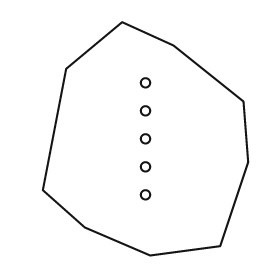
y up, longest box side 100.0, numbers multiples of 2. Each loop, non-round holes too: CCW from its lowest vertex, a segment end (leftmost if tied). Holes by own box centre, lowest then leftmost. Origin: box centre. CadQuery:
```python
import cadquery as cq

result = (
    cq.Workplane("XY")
    .moveTo(2.0, -50.0)
    .lineTo(32.0, -46.0)
    .lineTo(44.0, -10.0)
    .lineTo(42.0, 16.0)
    .lineTo(12.0, 40.0)
    .lineTo(-10.0, 50.0)
    .lineTo(-34.0, 30.0)
    .lineTo(-44.0, -22.0)
    .lineTo(-26.0, -38.0)
    .close()
    .moveTo(0.0, -24.0)
    .circle(2.0)
    .moveTo(0.0, -12.0)
    .circle(2.0)
    .moveTo(0.0, 0.0)
    .circle(2.0)
    .moveTo(0.0, 12.0)
    .circle(2.0)
    .moveTo(0.0, 24.0)
    .circle(2.0)
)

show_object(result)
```